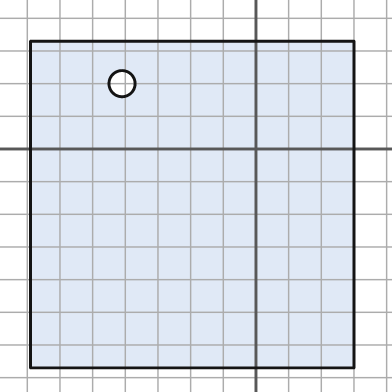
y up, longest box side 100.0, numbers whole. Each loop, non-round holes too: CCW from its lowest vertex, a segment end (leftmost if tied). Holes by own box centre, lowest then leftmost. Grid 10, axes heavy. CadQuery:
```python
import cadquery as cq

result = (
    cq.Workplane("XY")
    .moveTo(-69.0, -67.0)
    .lineTo(30.0, -67.0)
    .lineTo(30.0, 33.0)
    .lineTo(-69.0, 33.0)
    .close()
    .moveTo(-41.0, 20.0)
    .circle(4.0)
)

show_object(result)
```